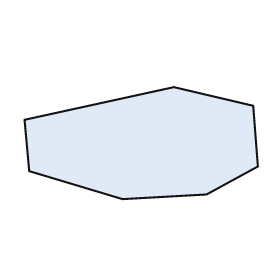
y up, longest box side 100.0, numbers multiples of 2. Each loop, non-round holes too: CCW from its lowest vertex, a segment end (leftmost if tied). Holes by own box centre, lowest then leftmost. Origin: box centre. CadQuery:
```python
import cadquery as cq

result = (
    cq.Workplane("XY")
    .moveTo(-8.0, -24.0)
    .lineTo(28.0, -22.0)
    .lineTo(50.0, -10.0)
    .lineTo(48.0, 16.0)
    .lineTo(14.0, 24.0)
    .lineTo(-50.0, 10.0)
    .lineTo(-48.0, -12.0)
    .close()
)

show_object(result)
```